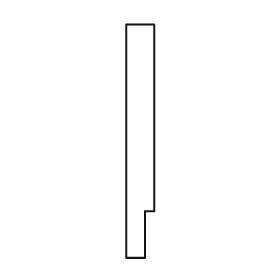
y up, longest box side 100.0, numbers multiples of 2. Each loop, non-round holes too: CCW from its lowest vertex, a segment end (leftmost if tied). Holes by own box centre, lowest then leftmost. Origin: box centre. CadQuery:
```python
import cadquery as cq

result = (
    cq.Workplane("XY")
    .moveTo(-6.0, -50.0)
    .lineTo(2.0, -50.0)
    .lineTo(2.0, -30.0)
    .lineTo(6.0, -30.0)
    .lineTo(6.0, 50.0)
    .lineTo(-6.0, 50.0)
    .close()
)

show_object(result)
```